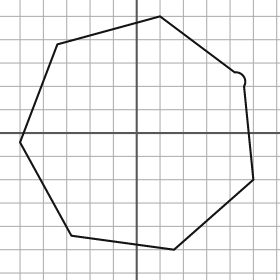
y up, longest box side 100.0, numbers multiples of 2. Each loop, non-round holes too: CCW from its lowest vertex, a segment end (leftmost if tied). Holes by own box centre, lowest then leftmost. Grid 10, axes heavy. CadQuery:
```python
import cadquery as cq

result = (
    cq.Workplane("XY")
    .moveTo(16.0, -50.0)
    .lineTo(50.0, -20.0)
    .lineTo(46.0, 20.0)
    .threePointArc((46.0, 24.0), (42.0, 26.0))
    .lineTo(10.0, 50.0)
    .lineTo(-34.0, 38.0)
    .lineTo(-50.0, -4.0)
    .lineTo(-28.0, -44.0)
    .close()
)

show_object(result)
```